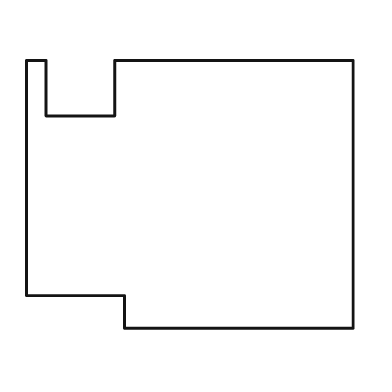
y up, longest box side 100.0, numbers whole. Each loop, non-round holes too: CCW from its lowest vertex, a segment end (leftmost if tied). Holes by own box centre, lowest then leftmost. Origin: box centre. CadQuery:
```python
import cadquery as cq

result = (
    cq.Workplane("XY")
    .moveTo(-20.0, -41.0)
    .lineTo(50.0, -41.0)
    .lineTo(50.0, 41.0)
    .lineTo(-23.0, 41.0)
    .lineTo(-23.0, 24.0)
    .lineTo(-44.0, 24.0)
    .lineTo(-44.0, 41.0)
    .lineTo(-50.0, 41.0)
    .lineTo(-50.0, -31.0)
    .lineTo(-20.0, -31.0)
    .close()
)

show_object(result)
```